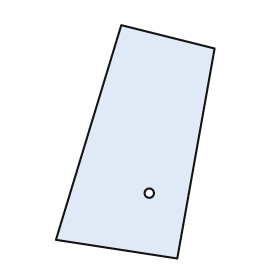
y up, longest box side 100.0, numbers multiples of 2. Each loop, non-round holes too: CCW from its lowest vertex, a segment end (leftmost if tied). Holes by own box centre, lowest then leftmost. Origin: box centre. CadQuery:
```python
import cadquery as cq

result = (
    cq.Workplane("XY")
    .moveTo(18.0, -50.0)
    .lineTo(34.0, 40.0)
    .lineTo(-6.0, 50.0)
    .lineTo(-34.0, -42.0)
    .close()
    .moveTo(6.0, -22.0)
    .circle(2.0)
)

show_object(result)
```